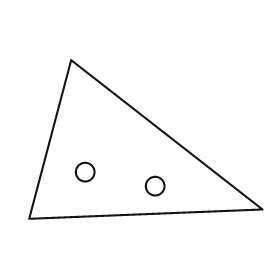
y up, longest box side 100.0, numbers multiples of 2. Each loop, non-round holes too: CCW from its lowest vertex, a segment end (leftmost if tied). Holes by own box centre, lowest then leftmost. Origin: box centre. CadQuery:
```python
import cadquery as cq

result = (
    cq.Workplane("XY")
    .moveTo(-50.0, -34.0)
    .lineTo(50.0, -30.0)
    .lineTo(-32.0, 34.0)
    .close()
    .moveTo(4.0, -20.0)
    .circle(4.0)
    .moveTo(-26.0, -14.0)
    .circle(4.0)
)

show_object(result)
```